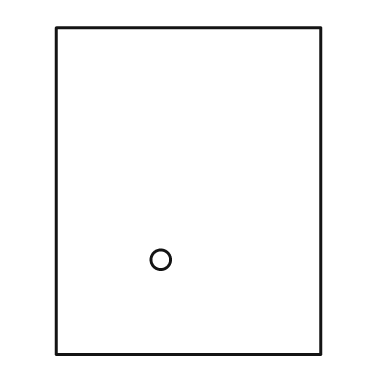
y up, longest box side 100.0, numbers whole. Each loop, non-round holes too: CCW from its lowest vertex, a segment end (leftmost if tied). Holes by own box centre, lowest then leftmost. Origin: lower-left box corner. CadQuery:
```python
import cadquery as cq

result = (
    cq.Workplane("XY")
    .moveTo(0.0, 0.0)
    .lineTo(81.0, 0.0)
    .lineTo(81.0, 100.0)
    .lineTo(0.0, 100.0)
    .close()
    .moveTo(32.0, 29.0)
    .circle(3.0)
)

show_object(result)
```